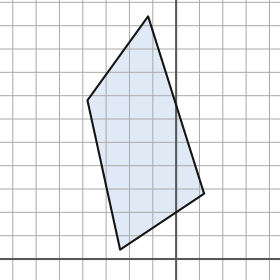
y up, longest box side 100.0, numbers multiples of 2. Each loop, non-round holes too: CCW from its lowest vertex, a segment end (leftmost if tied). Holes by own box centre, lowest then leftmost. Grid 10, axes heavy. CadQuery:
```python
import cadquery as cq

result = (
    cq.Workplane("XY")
    .moveTo(-24.0, 4.0)
    .lineTo(12.0, 28.0)
    .lineTo(-12.0, 104.0)
    .lineTo(-38.0, 68.0)
    .close()
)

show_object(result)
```